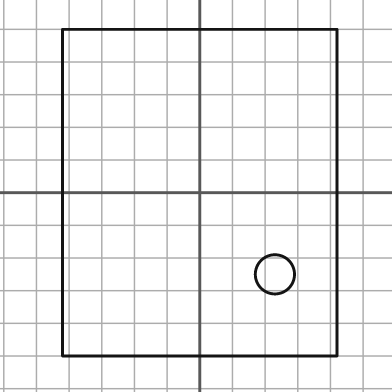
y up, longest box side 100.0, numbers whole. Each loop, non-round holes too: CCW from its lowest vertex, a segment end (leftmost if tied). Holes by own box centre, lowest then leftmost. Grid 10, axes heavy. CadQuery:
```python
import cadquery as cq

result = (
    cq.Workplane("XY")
    .moveTo(-42.0, -50.0)
    .lineTo(42.0, -50.0)
    .lineTo(42.0, 50.0)
    .lineTo(-42.0, 50.0)
    .close()
    .moveTo(23.0, -25.0)
    .circle(6.0)
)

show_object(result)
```